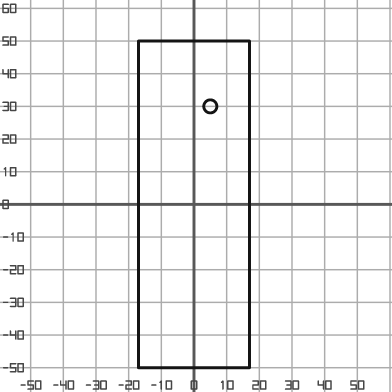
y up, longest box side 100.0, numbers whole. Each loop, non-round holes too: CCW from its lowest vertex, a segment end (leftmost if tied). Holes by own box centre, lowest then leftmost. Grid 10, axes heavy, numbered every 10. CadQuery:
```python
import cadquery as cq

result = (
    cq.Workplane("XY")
    .moveTo(-17.0, -50.0)
    .lineTo(17.0, -50.0)
    .lineTo(17.0, 50.0)
    .lineTo(-17.0, 50.0)
    .close()
    .moveTo(5.0, 30.0)
    .circle(2.0)
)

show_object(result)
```